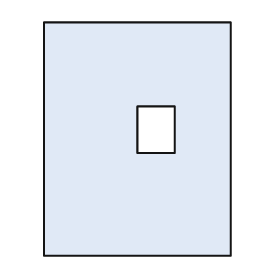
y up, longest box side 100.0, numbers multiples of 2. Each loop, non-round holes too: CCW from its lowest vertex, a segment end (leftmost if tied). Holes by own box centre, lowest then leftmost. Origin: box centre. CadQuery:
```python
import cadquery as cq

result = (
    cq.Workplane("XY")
    .moveTo(-40.0, -50.0)
    .lineTo(40.0, -50.0)
    .lineTo(40.0, 50.0)
    .lineTo(-40.0, 50.0)
    .close()
    .moveTo(0.0, -6.0)
    .lineTo(16.0, -6.0)
    .lineTo(16.0, 14.0)
    .lineTo(0.0, 14.0)
    .close()
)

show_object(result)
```